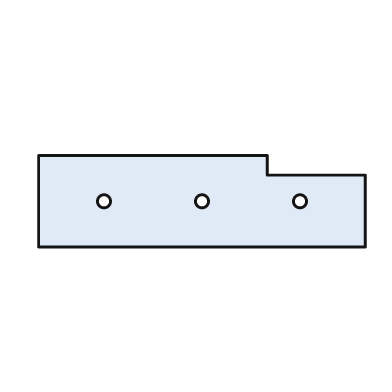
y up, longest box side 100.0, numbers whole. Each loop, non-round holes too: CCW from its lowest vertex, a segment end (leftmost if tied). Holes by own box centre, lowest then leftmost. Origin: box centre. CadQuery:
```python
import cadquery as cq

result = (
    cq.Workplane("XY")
    .moveTo(-50.0, -14.0)
    .lineTo(50.0, -14.0)
    .lineTo(50.0, 8.0)
    .lineTo(20.0, 8.0)
    .lineTo(20.0, 14.0)
    .lineTo(-50.0, 14.0)
    .close()
    .moveTo(-30.0, 0.0)
    .circle(2.0)
    .moveTo(0.0, 0.0)
    .circle(2.0)
    .moveTo(30.0, 0.0)
    .circle(2.0)
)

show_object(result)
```